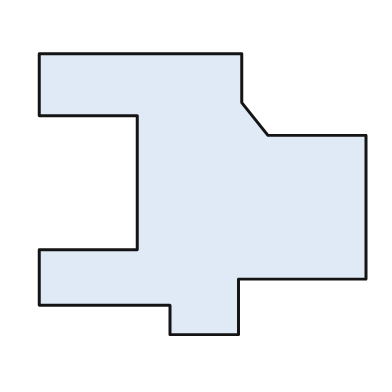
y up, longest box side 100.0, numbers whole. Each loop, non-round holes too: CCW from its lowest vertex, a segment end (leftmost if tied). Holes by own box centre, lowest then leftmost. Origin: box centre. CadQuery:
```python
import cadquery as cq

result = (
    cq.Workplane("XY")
    .moveTo(-10.0, -43.0)
    .lineTo(11.0, -43.0)
    .lineTo(11.0, -26.0)
    .lineTo(50.0, -26.0)
    .lineTo(50.0, 18.0)
    .lineTo(20.0, 18.0)
    .lineTo(12.0, 28.0)
    .lineTo(12.0, 43.0)
    .lineTo(-50.0, 43.0)
    .lineTo(-50.0, 24.0)
    .lineTo(-20.0, 24.0)
    .lineTo(-20.0, -17.0)
    .lineTo(-50.0, -17.0)
    .lineTo(-50.0, -34.0)
    .lineTo(-10.0, -34.0)
    .close()
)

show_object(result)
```